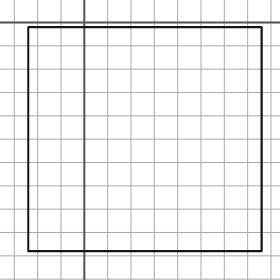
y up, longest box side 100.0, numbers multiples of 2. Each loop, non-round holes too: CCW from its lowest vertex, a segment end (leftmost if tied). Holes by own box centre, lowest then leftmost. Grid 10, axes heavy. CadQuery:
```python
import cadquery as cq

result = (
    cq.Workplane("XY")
    .moveTo(-24.0, -98.0)
    .lineTo(76.0, -98.0)
    .lineTo(76.0, -2.0)
    .lineTo(-24.0, -2.0)
    .close()
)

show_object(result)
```